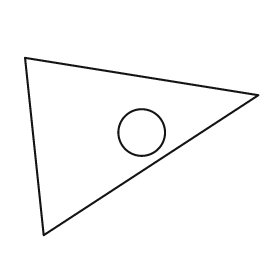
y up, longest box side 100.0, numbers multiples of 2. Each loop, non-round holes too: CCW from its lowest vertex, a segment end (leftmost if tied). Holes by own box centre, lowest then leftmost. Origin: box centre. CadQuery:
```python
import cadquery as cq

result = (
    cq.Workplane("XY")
    .moveTo(-42.0, -38.0)
    .lineTo(50.0, 22.0)
    .lineTo(-50.0, 38.0)
    .close()
    .moveTo(0.0, 6.0)
    .circle(10.0)
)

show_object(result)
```